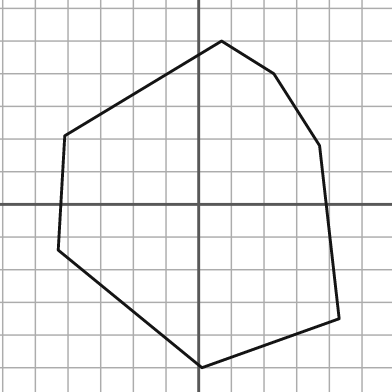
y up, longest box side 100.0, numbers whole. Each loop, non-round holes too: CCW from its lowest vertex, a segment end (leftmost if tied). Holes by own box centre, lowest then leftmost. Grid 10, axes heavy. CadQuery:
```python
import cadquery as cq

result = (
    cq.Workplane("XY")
    .moveTo(1.0, -50.0)
    .lineTo(43.0, -35.0)
    .lineTo(37.0, 18.0)
    .lineTo(23.0, 40.0)
    .lineTo(7.0, 50.0)
    .lineTo(-41.0, 21.0)
    .lineTo(-43.0, -14.0)
    .close()
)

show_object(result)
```